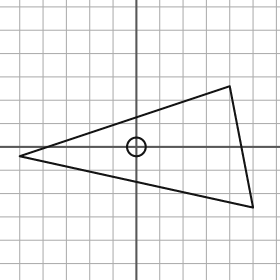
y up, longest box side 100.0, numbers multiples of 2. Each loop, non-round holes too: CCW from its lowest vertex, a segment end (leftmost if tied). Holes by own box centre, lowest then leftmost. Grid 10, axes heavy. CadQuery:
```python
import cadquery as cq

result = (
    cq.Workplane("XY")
    .moveTo(50.0, -26.0)
    .lineTo(40.0, 26.0)
    .lineTo(-50.0, -4.0)
    .close()
    .moveTo(0.0, 0.0)
    .circle(4.0)
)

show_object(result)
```